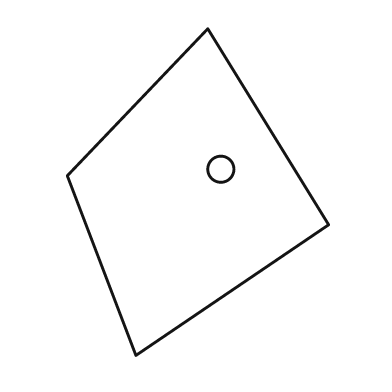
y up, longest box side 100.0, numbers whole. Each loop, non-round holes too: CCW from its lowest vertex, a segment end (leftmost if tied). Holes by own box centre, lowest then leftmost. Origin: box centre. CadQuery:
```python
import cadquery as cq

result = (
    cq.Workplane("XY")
    .moveTo(-19.0, -50.0)
    .lineTo(40.0, -10.0)
    .lineTo(3.0, 50.0)
    .lineTo(-40.0, 5.0)
    .close()
    .moveTo(7.0, 7.0)
    .circle(4.0)
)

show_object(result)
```